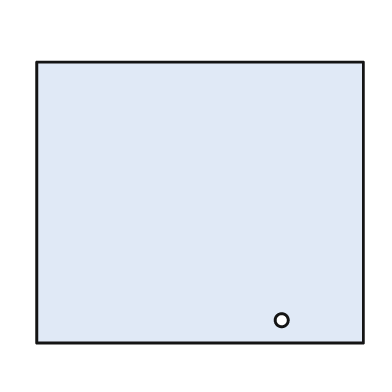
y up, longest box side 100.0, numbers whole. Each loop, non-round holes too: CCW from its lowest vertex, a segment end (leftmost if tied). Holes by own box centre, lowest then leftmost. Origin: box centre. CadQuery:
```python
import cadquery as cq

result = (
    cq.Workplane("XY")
    .moveTo(-50.0, -43.0)
    .lineTo(50.0, -43.0)
    .lineTo(50.0, 43.0)
    .lineTo(-50.0, 43.0)
    .close()
    .moveTo(25.0, -36.0)
    .circle(2.0)
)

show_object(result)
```